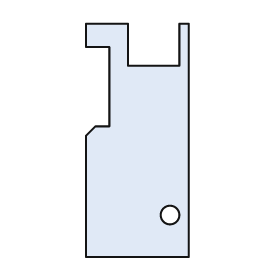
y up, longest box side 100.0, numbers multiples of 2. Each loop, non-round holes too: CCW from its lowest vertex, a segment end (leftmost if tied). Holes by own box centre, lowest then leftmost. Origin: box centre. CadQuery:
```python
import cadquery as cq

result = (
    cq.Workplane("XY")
    .moveTo(-22.0, -50.0)
    .lineTo(22.0, -50.0)
    .lineTo(22.0, 50.0)
    .lineTo(18.0, 50.0)
    .lineTo(18.0, 32.0)
    .lineTo(-4.0, 32.0)
    .lineTo(-4.0, 50.0)
    .lineTo(-22.0, 50.0)
    .lineTo(-22.0, 40.0)
    .lineTo(-12.0, 40.0)
    .lineTo(-12.0, 6.0)
    .lineTo(-18.0, 6.0)
    .lineTo(-22.0, 2.0)
    .close()
    .moveTo(14.0, -32.0)
    .circle(4.0)
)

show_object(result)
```